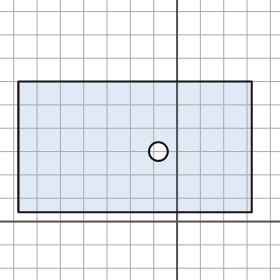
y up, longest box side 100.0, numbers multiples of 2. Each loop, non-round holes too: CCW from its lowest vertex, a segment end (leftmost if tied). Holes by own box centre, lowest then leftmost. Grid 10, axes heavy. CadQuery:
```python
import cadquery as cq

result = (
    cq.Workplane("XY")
    .moveTo(-68.0, 4.0)
    .lineTo(32.0, 4.0)
    .lineTo(32.0, 60.0)
    .lineTo(-68.0, 60.0)
    .close()
    .moveTo(-8.0, 30.0)
    .circle(4.0)
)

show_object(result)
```